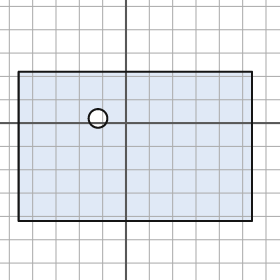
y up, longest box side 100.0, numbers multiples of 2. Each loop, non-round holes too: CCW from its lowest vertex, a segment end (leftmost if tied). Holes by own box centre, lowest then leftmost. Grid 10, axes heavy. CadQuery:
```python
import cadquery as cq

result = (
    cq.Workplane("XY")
    .moveTo(-46.0, -42.0)
    .lineTo(54.0, -42.0)
    .lineTo(54.0, 22.0)
    .lineTo(-46.0, 22.0)
    .close()
    .moveTo(-12.0, 2.0)
    .circle(4.0)
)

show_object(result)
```